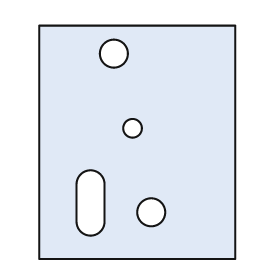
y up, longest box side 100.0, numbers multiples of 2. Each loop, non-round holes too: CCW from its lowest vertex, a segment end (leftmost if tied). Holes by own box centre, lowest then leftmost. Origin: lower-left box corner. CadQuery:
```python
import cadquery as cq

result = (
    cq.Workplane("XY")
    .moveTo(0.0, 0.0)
    .lineTo(84.0, 0.0)
    .lineTo(84.0, 100.0)
    .lineTo(0.0, 100.0)
    .close()
    .moveTo(48.0, 20.0)
    .circle(6.0)
    .moveTo(16.0, 16.0)
    .threePointArc((22.0, 10.0), (28.0, 16.0))
    .lineTo(28.0, 32.0)
    .threePointArc((22.0, 38.0), (16.0, 32.0))
    .close()
    .moveTo(40.0, 56.0)
    .circle(4.0)
    .moveTo(32.0, 88.0)
    .circle(6.0)
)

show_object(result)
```